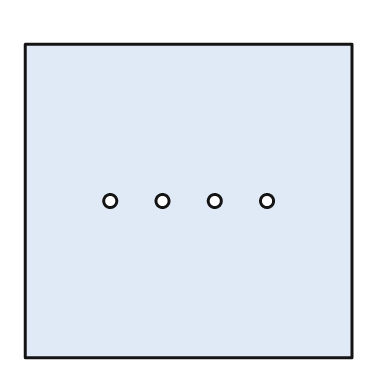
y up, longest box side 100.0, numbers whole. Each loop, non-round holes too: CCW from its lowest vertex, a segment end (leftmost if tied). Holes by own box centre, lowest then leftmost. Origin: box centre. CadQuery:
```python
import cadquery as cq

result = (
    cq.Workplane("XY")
    .moveTo(-50.0, -48.0)
    .lineTo(50.0, -48.0)
    .lineTo(50.0, 48.0)
    .lineTo(-50.0, 48.0)
    .close()
    .moveTo(-24.0, 0.0)
    .circle(2.0)
    .moveTo(-8.0, 0.0)
    .circle(2.0)
    .moveTo(8.0, 0.0)
    .circle(2.0)
    .moveTo(24.0, 0.0)
    .circle(2.0)
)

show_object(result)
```